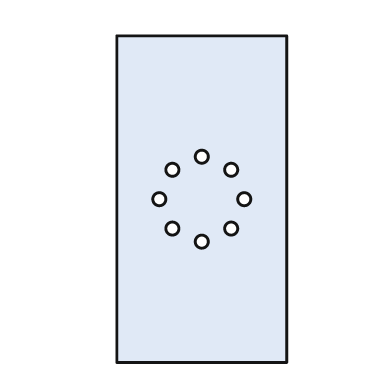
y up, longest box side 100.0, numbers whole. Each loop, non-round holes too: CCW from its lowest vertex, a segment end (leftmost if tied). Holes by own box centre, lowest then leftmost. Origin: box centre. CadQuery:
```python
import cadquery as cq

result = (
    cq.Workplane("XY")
    .moveTo(-26.0, -50.0)
    .lineTo(26.0, -50.0)
    .lineTo(26.0, 50.0)
    .lineTo(-26.0, 50.0)
    .close()
    .moveTo(0.0, -13.0)
    .circle(2.0)
    .moveTo(-9.0, -9.0)
    .circle(2.0)
    .moveTo(9.0, -9.0)
    .circle(2.0)
    .moveTo(-13.0, 0.0)
    .circle(2.0)
    .moveTo(13.0, 0.0)
    .circle(2.0)
    .moveTo(-9.0, 9.0)
    .circle(2.0)
    .moveTo(9.0, 9.0)
    .circle(2.0)
    .moveTo(0.0, 13.0)
    .circle(2.0)
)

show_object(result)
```